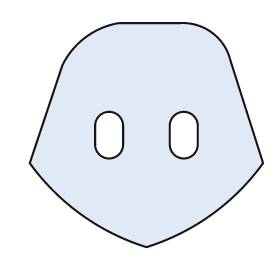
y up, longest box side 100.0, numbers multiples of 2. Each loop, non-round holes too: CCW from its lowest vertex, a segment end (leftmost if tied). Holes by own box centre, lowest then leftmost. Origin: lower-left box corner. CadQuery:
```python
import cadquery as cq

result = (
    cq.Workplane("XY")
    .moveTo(50.0, 0.0)
    .threePointArc((78.0, 14.0), (100.0, 36.0))
    .lineTo(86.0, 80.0)
    .threePointArc((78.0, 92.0), (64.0, 96.0))
    .lineTo(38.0, 96.0)
    .threePointArc((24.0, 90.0), (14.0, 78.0))
    .lineTo(0.0, 36.0)
    .threePointArc((22.0, 14.0), (50.0, 0.0))
    .close()
    .moveTo(28.0, 44.0)
    .threePointArc((34.0, 38.0), (40.0, 44.0))
    .lineTo(40.0, 52.0)
    .threePointArc((34.0, 58.0), (28.0, 52.0))
    .close()
    .moveTo(60.0, 44.0)
    .threePointArc((66.0, 38.0), (72.0, 44.0))
    .lineTo(72.0, 52.0)
    .threePointArc((66.0, 58.0), (60.0, 52.0))
    .close()
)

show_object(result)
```